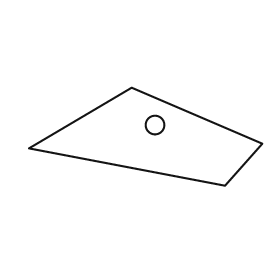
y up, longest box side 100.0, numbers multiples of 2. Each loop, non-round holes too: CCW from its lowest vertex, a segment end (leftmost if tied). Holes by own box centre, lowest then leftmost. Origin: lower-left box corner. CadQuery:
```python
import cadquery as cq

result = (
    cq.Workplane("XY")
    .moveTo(84.0, 0.0)
    .lineTo(100.0, 18.0)
    .lineTo(44.0, 42.0)
    .lineTo(0.0, 16.0)
    .close()
    .moveTo(54.0, 26.0)
    .circle(4.0)
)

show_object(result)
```